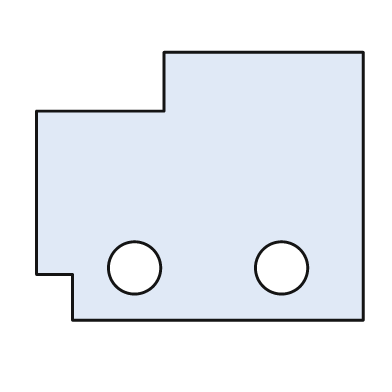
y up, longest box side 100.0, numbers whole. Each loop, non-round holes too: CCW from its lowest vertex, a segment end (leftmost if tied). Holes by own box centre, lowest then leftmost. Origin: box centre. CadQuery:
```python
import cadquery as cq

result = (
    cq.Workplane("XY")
    .moveTo(-39.0, -41.0)
    .lineTo(50.0, -41.0)
    .lineTo(50.0, 41.0)
    .lineTo(-11.0, 41.0)
    .lineTo(-11.0, 23.0)
    .lineTo(-50.0, 23.0)
    .lineTo(-50.0, -27.0)
    .lineTo(-39.0, -27.0)
    .close()
    .moveTo(-20.0, -25.0)
    .circle(8.0)
    .moveTo(25.0, -25.0)
    .circle(8.0)
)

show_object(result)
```